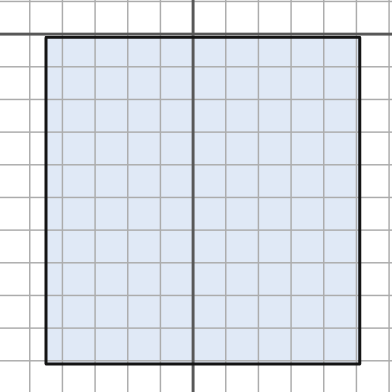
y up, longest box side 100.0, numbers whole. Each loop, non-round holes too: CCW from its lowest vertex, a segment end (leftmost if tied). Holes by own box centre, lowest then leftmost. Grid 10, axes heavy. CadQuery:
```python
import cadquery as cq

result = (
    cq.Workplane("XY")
    .moveTo(-45.0, -101.0)
    .lineTo(51.0, -101.0)
    .lineTo(51.0, -1.0)
    .lineTo(-45.0, -1.0)
    .close()
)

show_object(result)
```